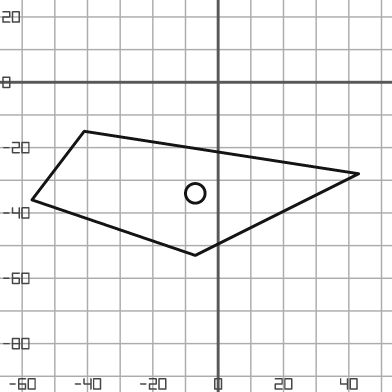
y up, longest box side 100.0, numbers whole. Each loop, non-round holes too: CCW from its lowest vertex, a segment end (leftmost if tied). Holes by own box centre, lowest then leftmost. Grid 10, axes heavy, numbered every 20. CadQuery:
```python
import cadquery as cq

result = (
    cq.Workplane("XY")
    .moveTo(-7.0, -53.0)
    .lineTo(43.0, -28.0)
    .lineTo(-41.0, -15.0)
    .lineTo(-57.0, -36.0)
    .close()
    .moveTo(-7.0, -34.0)
    .circle(3.0)
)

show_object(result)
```